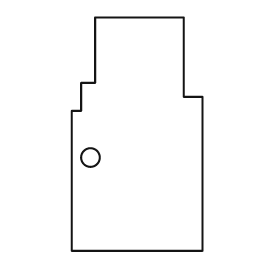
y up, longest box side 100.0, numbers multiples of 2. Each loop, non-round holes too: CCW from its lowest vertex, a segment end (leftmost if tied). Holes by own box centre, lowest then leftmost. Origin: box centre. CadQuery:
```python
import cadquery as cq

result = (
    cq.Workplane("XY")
    .moveTo(-28.0, -50.0)
    .lineTo(28.0, -50.0)
    .lineTo(28.0, 16.0)
    .lineTo(20.0, 16.0)
    .lineTo(20.0, 50.0)
    .lineTo(-18.0, 50.0)
    .lineTo(-18.0, 22.0)
    .lineTo(-24.0, 22.0)
    .lineTo(-24.0, 10.0)
    .lineTo(-28.0, 10.0)
    .close()
    .moveTo(-20.0, -10.0)
    .circle(4.0)
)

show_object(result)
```